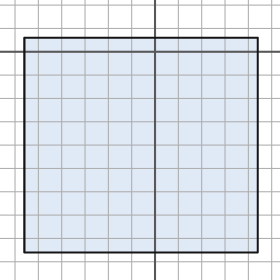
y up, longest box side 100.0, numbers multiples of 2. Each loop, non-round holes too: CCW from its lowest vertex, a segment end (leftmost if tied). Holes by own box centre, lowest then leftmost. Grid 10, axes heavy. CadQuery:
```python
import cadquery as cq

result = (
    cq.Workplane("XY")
    .moveTo(-56.0, -86.0)
    .lineTo(44.0, -86.0)
    .lineTo(44.0, 6.0)
    .lineTo(-56.0, 6.0)
    .close()
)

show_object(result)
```